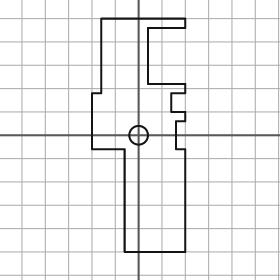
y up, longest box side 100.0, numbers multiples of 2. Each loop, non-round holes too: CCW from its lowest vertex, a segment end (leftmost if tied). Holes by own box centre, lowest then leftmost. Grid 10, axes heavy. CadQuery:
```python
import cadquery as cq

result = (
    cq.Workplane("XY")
    .moveTo(-6.0, -50.0)
    .lineTo(20.0, -50.0)
    .lineTo(20.0, -6.0)
    .lineTo(16.0, -6.0)
    .lineTo(16.0, 6.0)
    .lineTo(20.0, 6.0)
    .lineTo(20.0, 10.0)
    .lineTo(14.0, 10.0)
    .lineTo(14.0, 18.0)
    .lineTo(20.0, 18.0)
    .lineTo(20.0, 22.0)
    .lineTo(4.0, 22.0)
    .lineTo(4.0, 46.0)
    .lineTo(20.0, 46.0)
    .lineTo(20.0, 50.0)
    .lineTo(-16.0, 50.0)
    .lineTo(-16.0, 18.0)
    .lineTo(-20.0, 18.0)
    .lineTo(-20.0, -6.0)
    .lineTo(-6.0, -6.0)
    .close()
    .moveTo(0.0, 0.0)
    .circle(4.0)
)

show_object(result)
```